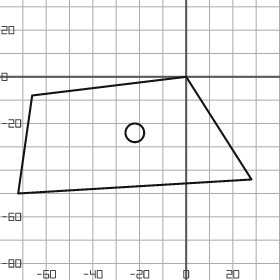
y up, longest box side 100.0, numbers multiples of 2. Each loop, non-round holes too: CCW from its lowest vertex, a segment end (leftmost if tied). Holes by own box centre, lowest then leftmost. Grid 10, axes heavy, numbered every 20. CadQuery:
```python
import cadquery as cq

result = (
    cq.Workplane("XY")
    .moveTo(-72.0, -50.0)
    .lineTo(28.0, -44.0)
    .lineTo(0.0, 0.0)
    .lineTo(-66.0, -8.0)
    .close()
    .moveTo(-22.0, -24.0)
    .circle(4.0)
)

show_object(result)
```